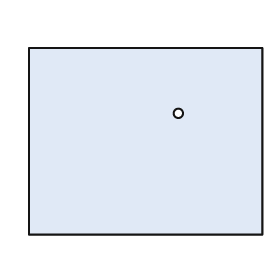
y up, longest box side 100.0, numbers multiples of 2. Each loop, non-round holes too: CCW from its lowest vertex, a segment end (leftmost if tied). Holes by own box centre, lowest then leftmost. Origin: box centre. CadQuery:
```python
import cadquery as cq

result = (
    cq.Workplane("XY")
    .moveTo(-50.0, -40.0)
    .lineTo(50.0, -40.0)
    .lineTo(50.0, 40.0)
    .lineTo(-50.0, 40.0)
    .close()
    .moveTo(14.0, 12.0)
    .circle(2.0)
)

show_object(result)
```